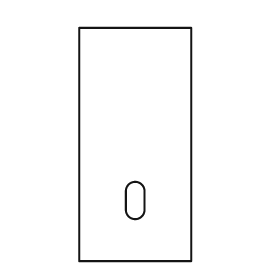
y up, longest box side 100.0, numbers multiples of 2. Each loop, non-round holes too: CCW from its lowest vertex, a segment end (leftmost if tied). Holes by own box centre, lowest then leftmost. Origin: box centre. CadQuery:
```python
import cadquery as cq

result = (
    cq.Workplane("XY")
    .moveTo(-24.0, -50.0)
    .lineTo(24.0, -50.0)
    .lineTo(24.0, 50.0)
    .lineTo(-24.0, 50.0)
    .close()
    .moveTo(-4.0, -28.0)
    .threePointArc((0.0, -32.0), (4.0, -28.0))
    .lineTo(4.0, -20.0)
    .threePointArc((0.0, -16.0), (-4.0, -20.0))
    .close()
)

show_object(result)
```